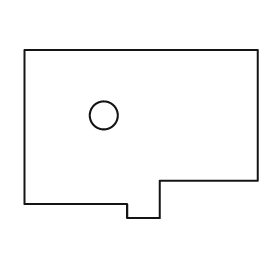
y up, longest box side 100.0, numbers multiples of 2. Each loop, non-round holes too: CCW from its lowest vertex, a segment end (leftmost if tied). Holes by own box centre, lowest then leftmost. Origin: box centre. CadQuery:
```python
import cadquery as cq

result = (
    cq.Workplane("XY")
    .moveTo(-6.0, -36.0)
    .lineTo(8.0, -36.0)
    .lineTo(8.0, -20.0)
    .lineTo(50.0, -20.0)
    .lineTo(50.0, 36.0)
    .lineTo(-50.0, 36.0)
    .lineTo(-50.0, -30.0)
    .lineTo(-6.0, -30.0)
    .close()
    .moveTo(-16.0, 8.0)
    .circle(6.0)
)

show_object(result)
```